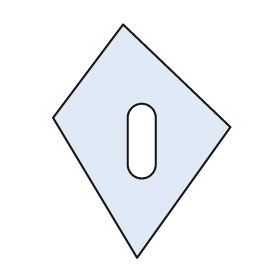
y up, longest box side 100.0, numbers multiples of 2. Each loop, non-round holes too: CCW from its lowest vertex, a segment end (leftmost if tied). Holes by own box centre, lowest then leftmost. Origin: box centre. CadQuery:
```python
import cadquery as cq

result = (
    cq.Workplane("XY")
    .moveTo(-2.0, -50.0)
    .lineTo(38.0, 6.0)
    .lineTo(-8.0, 50.0)
    .lineTo(-38.0, 10.0)
    .close()
    .moveTo(-6.0, -10.0)
    .threePointArc((0.0, -16.0), (6.0, -10.0))
    .lineTo(6.0, 10.0)
    .threePointArc((0.0, 16.0), (-6.0, 10.0))
    .close()
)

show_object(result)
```